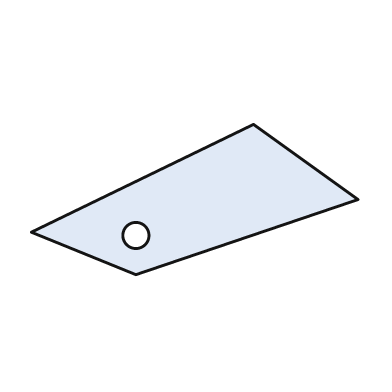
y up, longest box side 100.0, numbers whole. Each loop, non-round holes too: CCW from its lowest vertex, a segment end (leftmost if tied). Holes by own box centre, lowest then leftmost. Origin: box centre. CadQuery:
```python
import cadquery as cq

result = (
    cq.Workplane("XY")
    .moveTo(-18.0, -23.0)
    .lineTo(50.0, 0.0)
    .lineTo(18.0, 23.0)
    .lineTo(-50.0, -10.0)
    .close()
    .moveTo(-18.0, -11.0)
    .circle(4.0)
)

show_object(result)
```